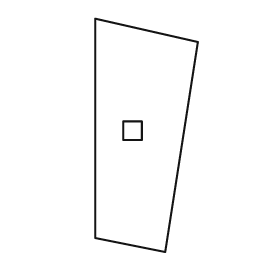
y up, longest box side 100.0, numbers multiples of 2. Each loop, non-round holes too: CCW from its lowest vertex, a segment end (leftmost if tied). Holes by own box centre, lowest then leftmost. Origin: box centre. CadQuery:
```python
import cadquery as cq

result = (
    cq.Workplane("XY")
    .moveTo(8.0, -50.0)
    .lineTo(22.0, 40.0)
    .lineTo(-22.0, 50.0)
    .lineTo(-22.0, -44.0)
    .close()
    .moveTo(-10.0, -2.0)
    .lineTo(-2.0, -2.0)
    .lineTo(-2.0, 6.0)
    .lineTo(-10.0, 6.0)
    .close()
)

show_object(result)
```